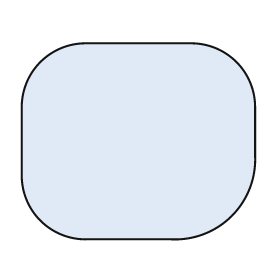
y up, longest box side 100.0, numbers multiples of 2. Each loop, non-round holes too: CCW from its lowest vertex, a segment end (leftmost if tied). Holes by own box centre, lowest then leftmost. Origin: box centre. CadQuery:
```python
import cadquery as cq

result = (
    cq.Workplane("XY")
    .moveTo(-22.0, -42.0)
    .lineTo(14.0, -42.0)
    .threePointArc((40.0, -32.0), (50.0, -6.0))
    .lineTo(50.0, 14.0)
    .threePointArc((42.0, 34.0), (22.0, 42.0))
    .lineTo(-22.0, 42.0)
    .threePointArc((-42.0, 34.0), (-50.0, 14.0))
    .lineTo(-50.0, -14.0)
    .threePointArc((-42.0, -34.0), (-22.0, -42.0))
    .close()
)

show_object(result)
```